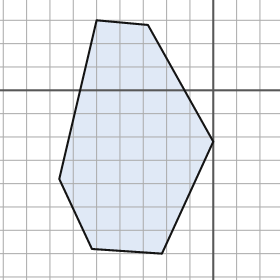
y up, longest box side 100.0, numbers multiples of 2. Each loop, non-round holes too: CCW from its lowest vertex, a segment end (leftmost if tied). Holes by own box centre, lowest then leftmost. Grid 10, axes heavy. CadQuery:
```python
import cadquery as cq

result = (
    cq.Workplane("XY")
    .moveTo(-22.0, -70.0)
    .lineTo(0.0, -22.0)
    .lineTo(-28.0, 28.0)
    .lineTo(-50.0, 30.0)
    .lineTo(-66.0, -38.0)
    .lineTo(-52.0, -68.0)
    .close()
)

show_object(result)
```